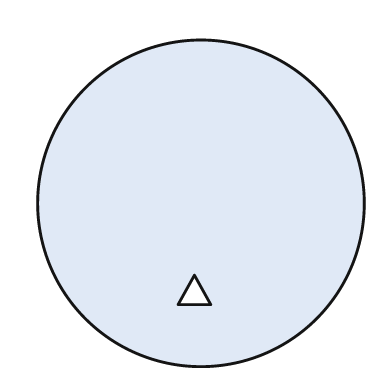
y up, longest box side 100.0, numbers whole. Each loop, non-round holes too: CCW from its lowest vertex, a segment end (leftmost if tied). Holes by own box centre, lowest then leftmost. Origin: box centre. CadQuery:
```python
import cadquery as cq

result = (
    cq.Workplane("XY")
    .moveTo(0.0, 0.0)
    .circle(50.0)
    .moveTo(-7.0, -31.0)
    .lineTo(3.0, -31.0)
    .lineTo(-2.0, -22.0)
    .close()
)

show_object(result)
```